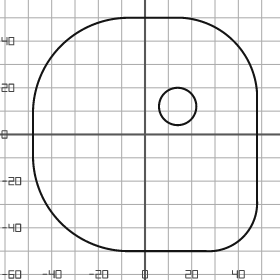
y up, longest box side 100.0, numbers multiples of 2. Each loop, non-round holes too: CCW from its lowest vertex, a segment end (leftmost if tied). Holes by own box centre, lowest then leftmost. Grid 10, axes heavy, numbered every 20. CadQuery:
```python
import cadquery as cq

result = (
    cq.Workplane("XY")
    .moveTo(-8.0, -50.0)
    .lineTo(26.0, -50.0)
    .threePointArc((42.0, -44.0), (48.0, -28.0))
    .lineTo(48.0, 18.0)
    .threePointArc((38.0, 40.0), (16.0, 50.0))
    .lineTo(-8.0, 50.0)
    .threePointArc((-36.0, 38.0), (-48.0, 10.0))
    .lineTo(-48.0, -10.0)
    .threePointArc((-36.0, -38.0), (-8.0, -50.0))
    .close()
    .moveTo(14.0, 12.0)
    .circle(8.0)
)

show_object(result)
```